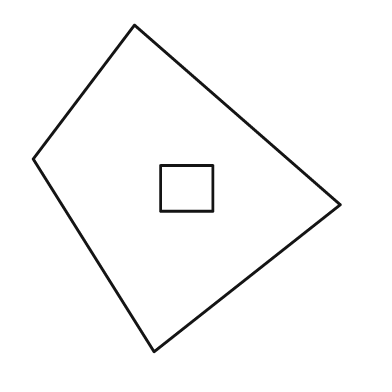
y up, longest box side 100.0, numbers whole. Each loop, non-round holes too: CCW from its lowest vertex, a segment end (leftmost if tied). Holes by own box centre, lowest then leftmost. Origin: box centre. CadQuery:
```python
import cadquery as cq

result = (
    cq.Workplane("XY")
    .moveTo(-10.0, -50.0)
    .lineTo(47.0, -5.0)
    .lineTo(-16.0, 50.0)
    .lineTo(-47.0, 9.0)
    .close()
    .moveTo(-8.0, -7.0)
    .lineTo(8.0, -7.0)
    .lineTo(8.0, 7.0)
    .lineTo(-8.0, 7.0)
    .close()
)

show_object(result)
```